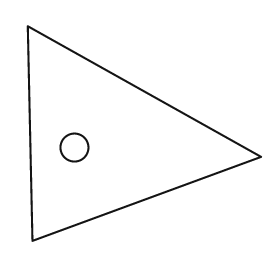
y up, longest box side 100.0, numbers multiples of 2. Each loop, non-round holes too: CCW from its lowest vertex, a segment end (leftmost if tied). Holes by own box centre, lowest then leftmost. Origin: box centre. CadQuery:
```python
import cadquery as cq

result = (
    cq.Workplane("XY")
    .moveTo(-48.0, -46.0)
    .lineTo(50.0, -10.0)
    .lineTo(-50.0, 46.0)
    .close()
    .moveTo(-30.0, -6.0)
    .circle(6.0)
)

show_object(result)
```